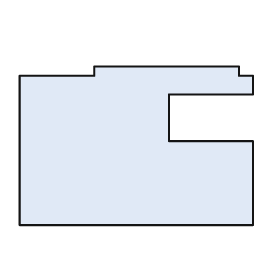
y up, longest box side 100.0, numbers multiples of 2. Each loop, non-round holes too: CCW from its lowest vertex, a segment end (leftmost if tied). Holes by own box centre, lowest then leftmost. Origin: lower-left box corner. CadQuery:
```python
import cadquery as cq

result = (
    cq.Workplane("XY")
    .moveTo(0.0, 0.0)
    .lineTo(100.0, 0.0)
    .lineTo(100.0, 36.0)
    .lineTo(64.0, 36.0)
    .lineTo(64.0, 56.0)
    .lineTo(100.0, 56.0)
    .lineTo(100.0, 64.0)
    .lineTo(94.0, 64.0)
    .lineTo(94.0, 68.0)
    .lineTo(32.0, 68.0)
    .lineTo(32.0, 64.0)
    .lineTo(0.0, 64.0)
    .close()
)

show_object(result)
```